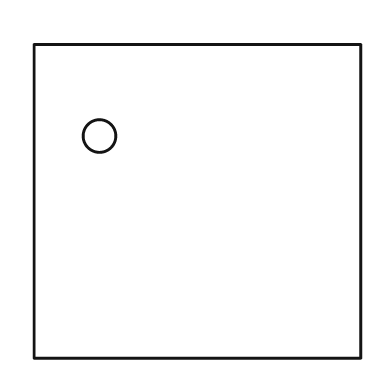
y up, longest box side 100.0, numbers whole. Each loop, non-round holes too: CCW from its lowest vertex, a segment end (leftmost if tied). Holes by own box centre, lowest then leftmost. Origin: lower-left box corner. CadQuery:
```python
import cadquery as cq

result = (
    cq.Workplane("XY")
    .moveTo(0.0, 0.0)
    .lineTo(100.0, 0.0)
    .lineTo(100.0, 96.0)
    .lineTo(0.0, 96.0)
    .close()
    .moveTo(20.0, 68.0)
    .circle(5.0)
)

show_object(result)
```